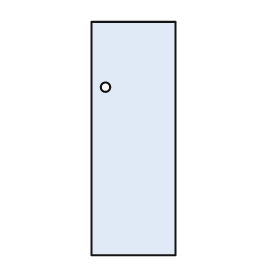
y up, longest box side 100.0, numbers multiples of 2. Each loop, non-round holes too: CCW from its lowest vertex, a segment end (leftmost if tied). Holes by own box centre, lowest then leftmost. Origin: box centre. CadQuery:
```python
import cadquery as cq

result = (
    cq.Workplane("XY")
    .moveTo(-18.0, -50.0)
    .lineTo(18.0, -50.0)
    .lineTo(18.0, 50.0)
    .lineTo(-18.0, 50.0)
    .close()
    .moveTo(-12.0, 22.0)
    .circle(2.0)
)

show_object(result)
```